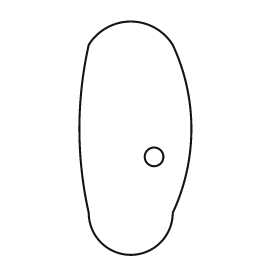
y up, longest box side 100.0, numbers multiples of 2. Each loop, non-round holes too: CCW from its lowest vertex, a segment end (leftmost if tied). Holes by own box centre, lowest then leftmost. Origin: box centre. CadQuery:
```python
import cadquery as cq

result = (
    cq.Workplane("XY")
    .moveTo(-20.0, -32.0)
    .threePointArc((-2.0, -50.0), (16.0, -32.0))
    .threePointArc((24.0, 4.0), (16.0, 40.0))
    .threePointArc((-2.0, 50.0), (-20.0, 40.0))
    .threePointArc((-24.0, 4.0), (-20.0, -32.0))
    .close()
    .moveTo(8.0, -8.0)
    .circle(4.0)
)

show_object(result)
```